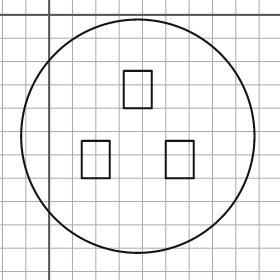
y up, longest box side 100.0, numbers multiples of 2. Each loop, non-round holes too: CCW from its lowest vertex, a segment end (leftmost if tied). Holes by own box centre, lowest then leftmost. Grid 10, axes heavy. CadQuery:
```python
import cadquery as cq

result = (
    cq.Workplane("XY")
    .moveTo(38.0, -52.0)
    .circle(50.0)
    .moveTo(14.0, -70.0)
    .lineTo(26.0, -70.0)
    .lineTo(26.0, -54.0)
    .lineTo(14.0, -54.0)
    .close()
    .moveTo(50.0, -70.0)
    .lineTo(62.0, -70.0)
    .lineTo(62.0, -54.0)
    .lineTo(50.0, -54.0)
    .close()
    .moveTo(32.0, -40.0)
    .lineTo(44.0, -40.0)
    .lineTo(44.0, -24.0)
    .lineTo(32.0, -24.0)
    .close()
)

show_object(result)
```